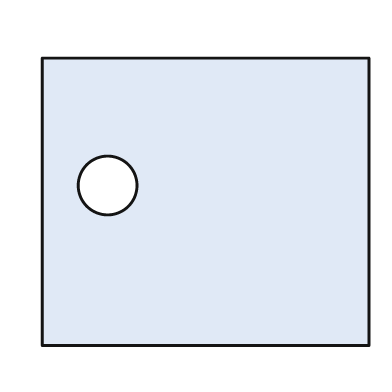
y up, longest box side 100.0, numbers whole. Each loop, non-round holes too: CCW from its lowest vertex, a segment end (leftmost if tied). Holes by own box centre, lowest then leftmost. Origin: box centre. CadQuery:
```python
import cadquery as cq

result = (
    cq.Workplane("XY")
    .moveTo(-50.0, -44.0)
    .lineTo(50.0, -44.0)
    .lineTo(50.0, 44.0)
    .lineTo(-50.0, 44.0)
    .close()
    .moveTo(-30.0, 5.0)
    .circle(9.0)
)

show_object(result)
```